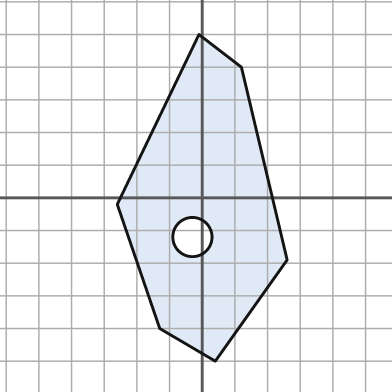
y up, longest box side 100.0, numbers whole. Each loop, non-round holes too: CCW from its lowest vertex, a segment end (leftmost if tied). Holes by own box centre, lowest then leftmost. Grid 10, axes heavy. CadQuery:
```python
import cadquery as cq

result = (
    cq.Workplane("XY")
    .moveTo(4.0, -50.0)
    .lineTo(26.0, -19.0)
    .lineTo(12.0, 40.0)
    .lineTo(-1.0, 50.0)
    .lineTo(-26.0, -2.0)
    .lineTo(-13.0, -40.0)
    .close()
    .moveTo(-3.0, -12.0)
    .circle(6.0)
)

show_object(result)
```